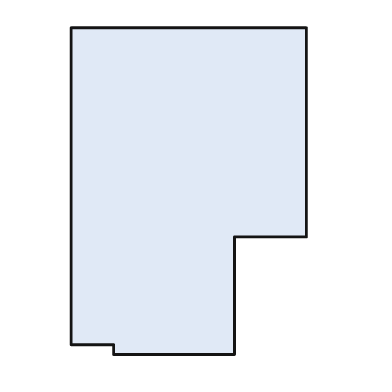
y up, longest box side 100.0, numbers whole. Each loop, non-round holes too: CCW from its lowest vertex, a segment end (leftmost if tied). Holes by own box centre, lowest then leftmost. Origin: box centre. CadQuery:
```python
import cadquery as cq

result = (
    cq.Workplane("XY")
    .moveTo(-23.0, -50.0)
    .lineTo(14.0, -50.0)
    .lineTo(14.0, -14.0)
    .lineTo(36.0, -14.0)
    .lineTo(36.0, 50.0)
    .lineTo(-36.0, 50.0)
    .lineTo(-36.0, -47.0)
    .lineTo(-23.0, -47.0)
    .close()
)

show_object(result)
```